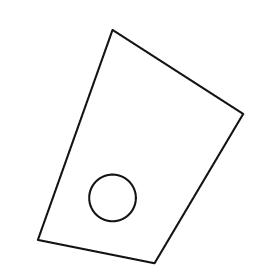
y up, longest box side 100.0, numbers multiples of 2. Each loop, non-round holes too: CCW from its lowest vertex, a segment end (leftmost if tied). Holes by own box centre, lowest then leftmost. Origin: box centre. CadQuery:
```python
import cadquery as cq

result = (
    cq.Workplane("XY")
    .moveTo(6.0, -50.0)
    .lineTo(44.0, 14.0)
    .lineTo(-12.0, 50.0)
    .lineTo(-44.0, -40.0)
    .close()
    .moveTo(-12.0, -22.0)
    .circle(10.0)
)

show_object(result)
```